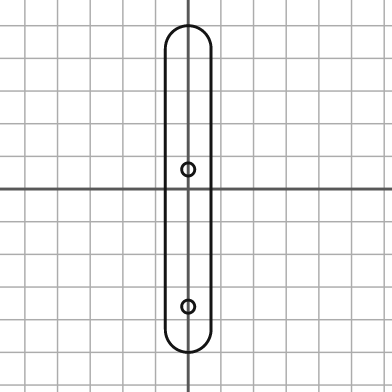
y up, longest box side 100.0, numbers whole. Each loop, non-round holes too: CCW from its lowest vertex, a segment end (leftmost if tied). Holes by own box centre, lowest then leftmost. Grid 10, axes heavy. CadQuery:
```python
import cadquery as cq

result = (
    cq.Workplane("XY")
    .moveTo(-7.0, -43.0)
    .threePointArc((0.0, -50.0), (7.0, -43.0))
    .lineTo(7.0, 43.0)
    .threePointArc((0.0, 50.0), (-7.0, 43.0))
    .close()
    .moveTo(0.0, -36.0)
    .circle(2.0)
    .moveTo(0.0, 6.0)
    .circle(2.0)
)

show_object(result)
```